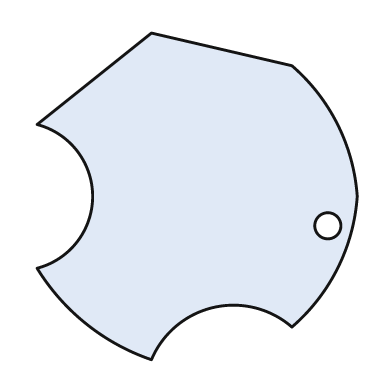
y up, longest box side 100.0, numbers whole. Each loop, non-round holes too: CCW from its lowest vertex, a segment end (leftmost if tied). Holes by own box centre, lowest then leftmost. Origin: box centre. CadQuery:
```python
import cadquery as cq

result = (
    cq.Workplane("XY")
    .moveTo(-14.0, -50.0)
    .threePointArc((5.0, -34.0), (29.0, -40.0))
    .threePointArc((43.0, -22.0), (49.0, 0.0))
    .threePointArc((43.0, 22.0), (29.0, 40.0))
    .lineTo(-14.0, 50.0)
    .lineTo(-49.0, 22.0)
    .threePointArc((-32.0, 0.0), (-49.0, -22.0))
    .threePointArc((-34.0, -39.0), (-14.0, -50.0))
    .close()
    .moveTo(40.0, -9.0)
    .circle(4.0)
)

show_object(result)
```